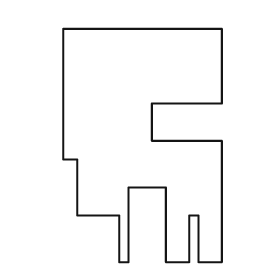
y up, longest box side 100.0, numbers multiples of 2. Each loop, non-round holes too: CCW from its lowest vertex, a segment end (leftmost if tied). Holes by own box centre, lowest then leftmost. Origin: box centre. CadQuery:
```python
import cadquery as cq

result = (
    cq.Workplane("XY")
    .moveTo(-10.0, -50.0)
    .lineTo(-6.0, -50.0)
    .lineTo(-6.0, -18.0)
    .lineTo(10.0, -18.0)
    .lineTo(10.0, -50.0)
    .lineTo(20.0, -50.0)
    .lineTo(20.0, -30.0)
    .lineTo(24.0, -30.0)
    .lineTo(24.0, -50.0)
    .lineTo(34.0, -50.0)
    .lineTo(34.0, 2.0)
    .lineTo(4.0, 2.0)
    .lineTo(4.0, 18.0)
    .lineTo(34.0, 18.0)
    .lineTo(34.0, 50.0)
    .lineTo(-34.0, 50.0)
    .lineTo(-34.0, -6.0)
    .lineTo(-28.0, -6.0)
    .lineTo(-28.0, -30.0)
    .lineTo(-10.0, -30.0)
    .close()
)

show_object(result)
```